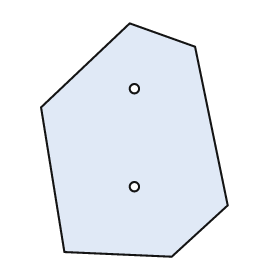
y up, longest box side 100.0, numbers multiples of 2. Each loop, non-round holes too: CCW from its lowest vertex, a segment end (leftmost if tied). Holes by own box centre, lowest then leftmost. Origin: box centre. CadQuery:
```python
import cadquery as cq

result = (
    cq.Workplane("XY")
    .moveTo(16.0, -50.0)
    .lineTo(40.0, -28.0)
    .lineTo(26.0, 40.0)
    .lineTo(-2.0, 50.0)
    .lineTo(-40.0, 14.0)
    .lineTo(-30.0, -48.0)
    .close()
    .moveTo(0.0, -20.0)
    .circle(2.0)
    .moveTo(0.0, 22.0)
    .circle(2.0)
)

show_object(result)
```